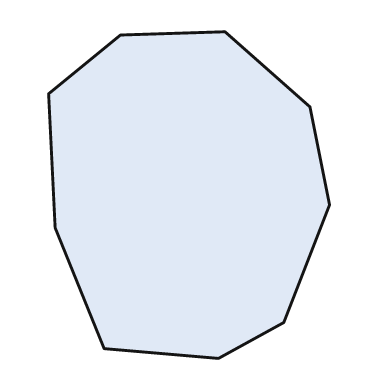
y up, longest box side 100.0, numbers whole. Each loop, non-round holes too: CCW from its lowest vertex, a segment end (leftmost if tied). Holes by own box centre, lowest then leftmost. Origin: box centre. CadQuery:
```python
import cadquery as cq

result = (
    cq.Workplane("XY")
    .moveTo(9.0, -50.0)
    .lineTo(29.0, -39.0)
    .lineTo(43.0, -3.0)
    .lineTo(37.0, 27.0)
    .lineTo(11.0, 50.0)
    .lineTo(-21.0, 49.0)
    .lineTo(-43.0, 31.0)
    .lineTo(-41.0, -10.0)
    .lineTo(-26.0, -47.0)
    .close()
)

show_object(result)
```